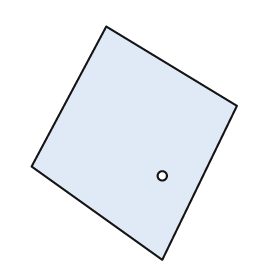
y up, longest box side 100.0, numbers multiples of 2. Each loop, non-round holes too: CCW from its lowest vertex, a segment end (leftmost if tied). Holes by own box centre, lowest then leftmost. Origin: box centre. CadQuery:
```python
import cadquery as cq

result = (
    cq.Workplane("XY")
    .moveTo(12.0, -50.0)
    .lineTo(44.0, 16.0)
    .lineTo(-12.0, 50.0)
    .lineTo(-44.0, -10.0)
    .close()
    .moveTo(12.0, -14.0)
    .circle(2.0)
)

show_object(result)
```